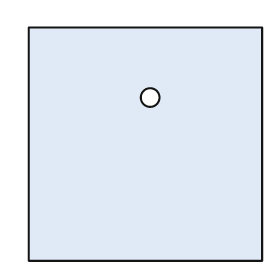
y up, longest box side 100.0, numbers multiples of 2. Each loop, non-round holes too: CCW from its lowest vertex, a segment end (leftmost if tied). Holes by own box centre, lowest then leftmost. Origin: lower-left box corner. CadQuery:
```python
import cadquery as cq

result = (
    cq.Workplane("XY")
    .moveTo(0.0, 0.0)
    .lineTo(100.0, 0.0)
    .lineTo(100.0, 100.0)
    .lineTo(0.0, 100.0)
    .close()
    .moveTo(52.0, 70.0)
    .circle(4.0)
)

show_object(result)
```